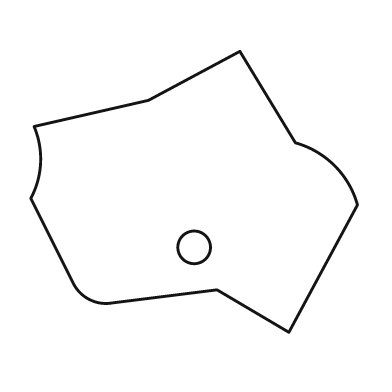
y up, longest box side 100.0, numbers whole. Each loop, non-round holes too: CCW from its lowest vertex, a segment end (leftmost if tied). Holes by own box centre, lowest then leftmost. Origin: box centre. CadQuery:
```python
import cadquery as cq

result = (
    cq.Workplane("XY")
    .moveTo(29.0, -43.0)
    .lineTo(50.0, -4.0)
    .threePointArc((43.0, 8.0), (31.0, 15.0))
    .lineTo(14.0, 43.0)
    .lineTo(-14.0, 28.0)
    .lineTo(-49.0, 20.0)
    .threePointArc((-47.0, 9.0), (-50.0, -2.0))
    .lineTo(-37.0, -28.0)
    .threePointArc((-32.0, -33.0), (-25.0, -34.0))
    .lineTo(7.0, -30.0)
    .close()
    .moveTo(0.0, -17.0)
    .circle(5.0)
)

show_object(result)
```